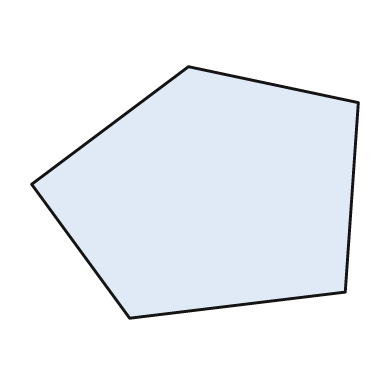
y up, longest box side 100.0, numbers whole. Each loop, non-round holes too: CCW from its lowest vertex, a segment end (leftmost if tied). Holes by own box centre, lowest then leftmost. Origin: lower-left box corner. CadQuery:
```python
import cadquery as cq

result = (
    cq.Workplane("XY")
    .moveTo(30.0, 0.0)
    .lineTo(96.0, 8.0)
    .lineTo(100.0, 66.0)
    .lineTo(48.0, 77.0)
    .lineTo(0.0, 41.0)
    .close()
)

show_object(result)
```